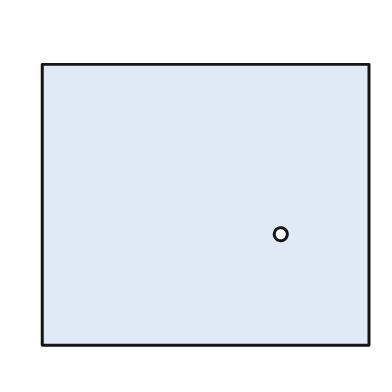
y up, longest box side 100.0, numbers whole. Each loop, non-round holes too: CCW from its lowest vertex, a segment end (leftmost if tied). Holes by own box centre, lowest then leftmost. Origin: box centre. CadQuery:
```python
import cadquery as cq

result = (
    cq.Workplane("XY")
    .moveTo(-50.0, -43.0)
    .lineTo(50.0, -43.0)
    .lineTo(50.0, 43.0)
    .lineTo(-50.0, 43.0)
    .close()
    .moveTo(23.0, -9.0)
    .circle(2.0)
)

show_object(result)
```